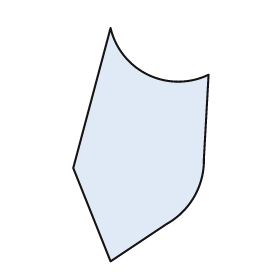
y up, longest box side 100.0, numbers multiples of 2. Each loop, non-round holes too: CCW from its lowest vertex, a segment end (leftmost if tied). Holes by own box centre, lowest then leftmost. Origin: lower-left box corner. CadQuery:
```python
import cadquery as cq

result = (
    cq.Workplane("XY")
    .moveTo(16.0, 0.0)
    .lineTo(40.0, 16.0)
    .threePointArc((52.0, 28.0), (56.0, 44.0))
    .lineTo(58.0, 80.0)
    .threePointArc((32.0, 80.0), (16.0, 100.0))
    .lineTo(0.0, 40.0)
    .close()
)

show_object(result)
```